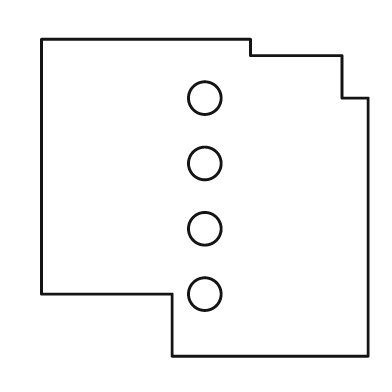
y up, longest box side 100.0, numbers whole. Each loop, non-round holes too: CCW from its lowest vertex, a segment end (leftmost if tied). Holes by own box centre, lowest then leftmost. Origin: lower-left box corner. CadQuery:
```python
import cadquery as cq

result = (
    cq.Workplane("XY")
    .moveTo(40.0, 0.0)
    .lineTo(100.0, 0.0)
    .lineTo(100.0, 79.0)
    .lineTo(92.0, 79.0)
    .lineTo(92.0, 92.0)
    .lineTo(64.0, 92.0)
    .lineTo(64.0, 97.0)
    .lineTo(0.0, 97.0)
    .lineTo(0.0, 19.0)
    .lineTo(40.0, 19.0)
    .close()
    .moveTo(50.0, 19.0)
    .circle(5.0)
    .moveTo(50.0, 39.0)
    .circle(5.0)
    .moveTo(50.0, 59.0)
    .circle(5.0)
    .moveTo(50.0, 79.0)
    .circle(5.0)
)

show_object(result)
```